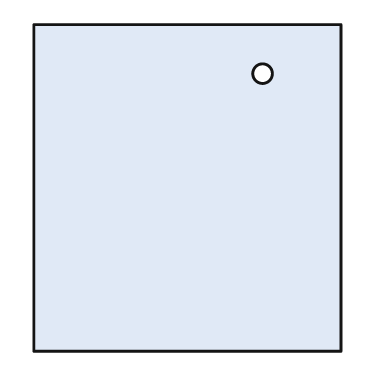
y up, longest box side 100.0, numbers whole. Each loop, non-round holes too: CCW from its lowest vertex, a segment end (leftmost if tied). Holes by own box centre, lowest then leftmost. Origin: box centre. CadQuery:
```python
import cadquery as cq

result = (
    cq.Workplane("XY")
    .moveTo(-47.0, -50.0)
    .lineTo(47.0, -50.0)
    .lineTo(47.0, 50.0)
    .lineTo(-47.0, 50.0)
    .close()
    .moveTo(23.0, 35.0)
    .circle(3.0)
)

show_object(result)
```